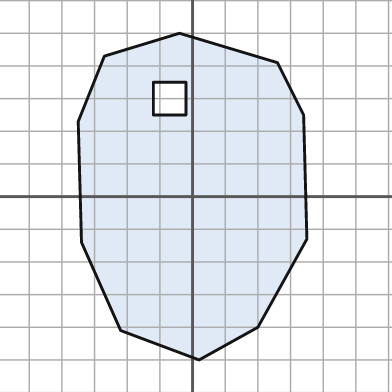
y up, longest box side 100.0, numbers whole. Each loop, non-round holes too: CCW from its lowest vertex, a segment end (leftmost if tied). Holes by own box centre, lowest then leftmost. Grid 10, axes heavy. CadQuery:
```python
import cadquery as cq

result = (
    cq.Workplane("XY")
    .moveTo(2.0, -50.0)
    .lineTo(20.0, -40.0)
    .lineTo(35.0, -13.0)
    .lineTo(34.0, 25.0)
    .lineTo(26.0, 41.0)
    .lineTo(-4.0, 50.0)
    .lineTo(-27.0, 43.0)
    .lineTo(-35.0, 23.0)
    .lineTo(-34.0, -14.0)
    .lineTo(-22.0, -41.0)
    .close()
    .moveTo(-12.0, 25.0)
    .lineTo(-2.0, 25.0)
    .lineTo(-2.0, 35.0)
    .lineTo(-12.0, 35.0)
    .close()
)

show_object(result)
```